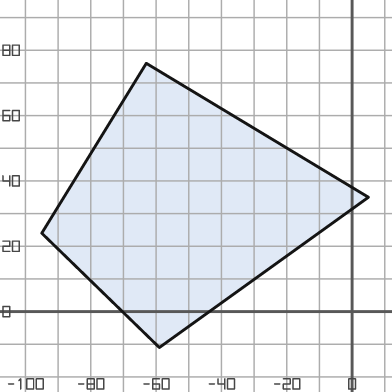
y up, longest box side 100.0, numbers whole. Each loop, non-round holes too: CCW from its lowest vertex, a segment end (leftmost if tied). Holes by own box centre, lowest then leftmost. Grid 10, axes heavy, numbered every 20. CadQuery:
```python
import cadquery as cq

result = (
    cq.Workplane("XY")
    .moveTo(-59.0, -11.0)
    .lineTo(5.0, 35.0)
    .lineTo(-63.0, 76.0)
    .lineTo(-95.0, 24.0)
    .close()
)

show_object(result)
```